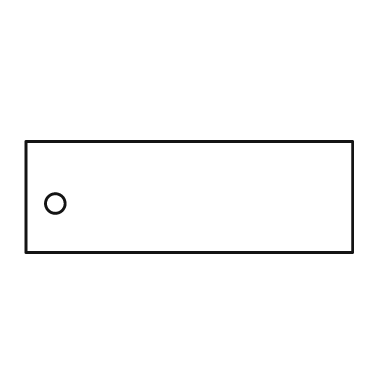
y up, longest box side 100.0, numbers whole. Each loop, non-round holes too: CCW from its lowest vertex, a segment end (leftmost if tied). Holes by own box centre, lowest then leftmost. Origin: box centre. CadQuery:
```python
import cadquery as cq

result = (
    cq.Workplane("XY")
    .moveTo(-50.0, -17.0)
    .lineTo(50.0, -17.0)
    .lineTo(50.0, 17.0)
    .lineTo(-50.0, 17.0)
    .close()
    .moveTo(-41.0, -2.0)
    .circle(3.0)
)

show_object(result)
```